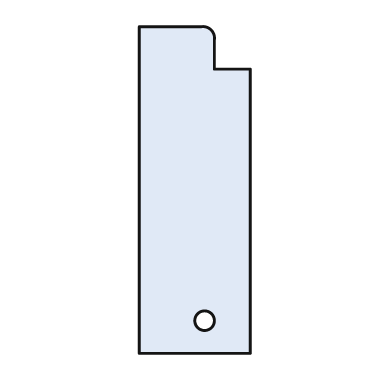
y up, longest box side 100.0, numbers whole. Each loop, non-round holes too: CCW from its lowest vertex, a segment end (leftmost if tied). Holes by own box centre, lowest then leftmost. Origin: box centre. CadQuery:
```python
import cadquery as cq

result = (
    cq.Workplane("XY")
    .moveTo(-17.0, -50.0)
    .lineTo(17.0, -50.0)
    .lineTo(17.0, 37.0)
    .lineTo(6.0, 37.0)
    .lineTo(6.0, 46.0)
    .threePointArc((5.0, 49.0), (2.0, 50.0))
    .lineTo(-17.0, 50.0)
    .close()
    .moveTo(3.0, -40.0)
    .circle(3.0)
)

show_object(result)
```